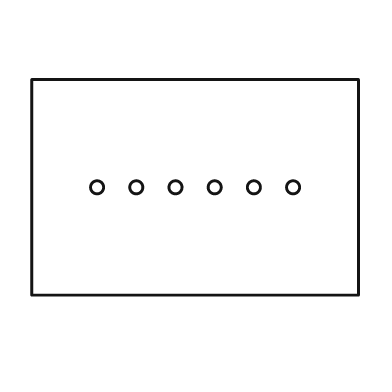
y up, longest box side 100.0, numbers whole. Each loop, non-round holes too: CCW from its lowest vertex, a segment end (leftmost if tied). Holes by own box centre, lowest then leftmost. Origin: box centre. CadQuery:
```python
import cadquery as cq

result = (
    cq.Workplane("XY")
    .moveTo(-50.0, -33.0)
    .lineTo(50.0, -33.0)
    .lineTo(50.0, 33.0)
    .lineTo(-50.0, 33.0)
    .close()
    .moveTo(-30.0, 0.0)
    .circle(2.0)
    .moveTo(-18.0, 0.0)
    .circle(2.0)
    .moveTo(-6.0, 0.0)
    .circle(2.0)
    .moveTo(6.0, 0.0)
    .circle(2.0)
    .moveTo(18.0, 0.0)
    .circle(2.0)
    .moveTo(30.0, 0.0)
    .circle(2.0)
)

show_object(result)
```